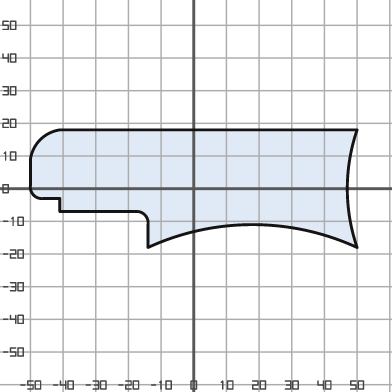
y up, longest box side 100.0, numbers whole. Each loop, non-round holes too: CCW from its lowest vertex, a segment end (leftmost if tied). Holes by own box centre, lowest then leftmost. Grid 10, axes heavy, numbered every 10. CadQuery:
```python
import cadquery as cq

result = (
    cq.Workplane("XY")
    .moveTo(-14.0, -18.0)
    .threePointArc((18.0, -11.0), (50.0, -18.0))
    .threePointArc((47.0, 0.0), (50.0, 18.0))
    .lineTo(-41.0, 18.0)
    .threePointArc((-47.0, 15.0), (-50.0, 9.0))
    .lineTo(-50.0, 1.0)
    .threePointArc((-49.0, -2.0), (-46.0, -3.0))
    .lineTo(-41.0, -3.0)
    .lineTo(-41.0, -7.0)
    .lineTo(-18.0, -7.0)
    .threePointArc((-15.0, -8.0), (-14.0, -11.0))
    .close()
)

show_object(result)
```